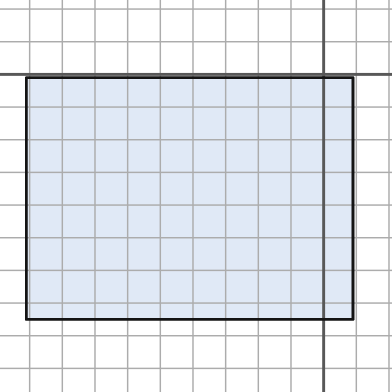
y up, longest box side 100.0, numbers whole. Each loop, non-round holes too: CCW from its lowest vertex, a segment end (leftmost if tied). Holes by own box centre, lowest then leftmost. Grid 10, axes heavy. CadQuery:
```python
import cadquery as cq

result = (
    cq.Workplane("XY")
    .moveTo(-91.0, -75.0)
    .lineTo(9.0, -75.0)
    .lineTo(9.0, -1.0)
    .lineTo(-91.0, -1.0)
    .close()
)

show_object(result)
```